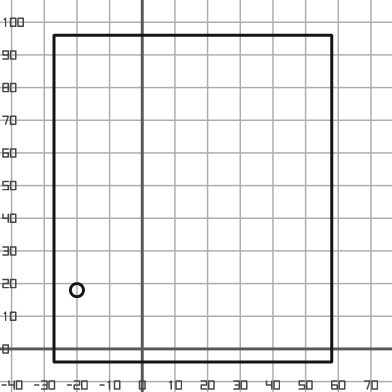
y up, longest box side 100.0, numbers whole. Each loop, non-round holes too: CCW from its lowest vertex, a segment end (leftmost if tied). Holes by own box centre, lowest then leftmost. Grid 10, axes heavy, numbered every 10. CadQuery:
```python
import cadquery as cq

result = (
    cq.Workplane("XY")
    .moveTo(-27.0, -4.0)
    .lineTo(58.0, -4.0)
    .lineTo(58.0, 96.0)
    .lineTo(-27.0, 96.0)
    .close()
    .moveTo(-20.0, 18.0)
    .circle(2.0)
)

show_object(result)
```